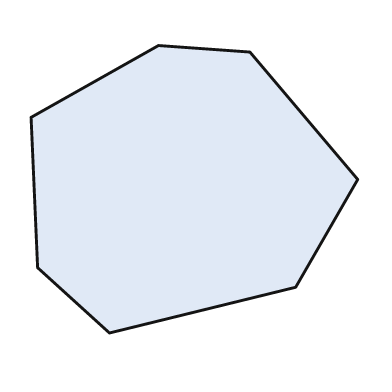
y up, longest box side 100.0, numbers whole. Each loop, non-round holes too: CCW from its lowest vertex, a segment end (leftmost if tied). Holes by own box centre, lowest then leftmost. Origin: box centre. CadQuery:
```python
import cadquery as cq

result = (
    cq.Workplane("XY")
    .moveTo(-26.0, -44.0)
    .lineTo(31.0, -30.0)
    .lineTo(50.0, 3.0)
    .lineTo(17.0, 42.0)
    .lineTo(-11.0, 44.0)
    .lineTo(-50.0, 22.0)
    .lineTo(-48.0, -24.0)
    .close()
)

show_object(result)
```